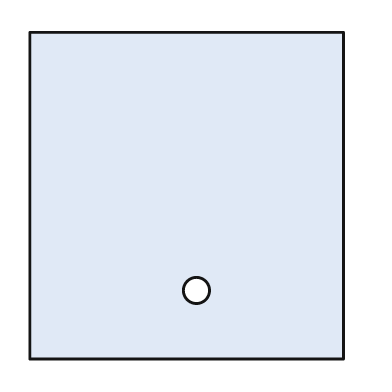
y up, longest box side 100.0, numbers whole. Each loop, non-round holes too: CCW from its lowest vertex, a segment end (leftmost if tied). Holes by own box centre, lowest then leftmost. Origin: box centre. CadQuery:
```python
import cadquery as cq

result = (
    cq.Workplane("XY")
    .moveTo(-48.0, -50.0)
    .lineTo(48.0, -50.0)
    .lineTo(48.0, 50.0)
    .lineTo(-48.0, 50.0)
    .close()
    .moveTo(3.0, -29.0)
    .circle(4.0)
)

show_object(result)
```